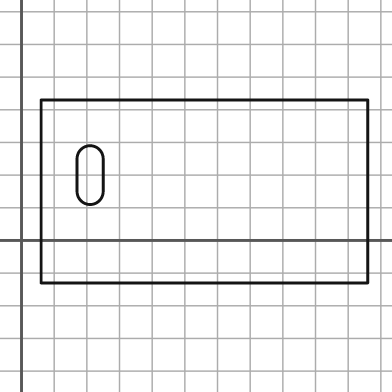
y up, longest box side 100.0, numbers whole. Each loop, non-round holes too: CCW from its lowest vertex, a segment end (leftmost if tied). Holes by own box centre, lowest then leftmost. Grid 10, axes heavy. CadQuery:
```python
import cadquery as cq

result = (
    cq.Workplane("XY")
    .moveTo(6.0, -13.0)
    .lineTo(106.0, -13.0)
    .lineTo(106.0, 43.0)
    .lineTo(6.0, 43.0)
    .close()
    .moveTo(17.0, 15.0)
    .threePointArc((21.0, 11.0), (25.0, 15.0))
    .lineTo(25.0, 25.0)
    .threePointArc((21.0, 29.0), (17.0, 25.0))
    .close()
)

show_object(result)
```